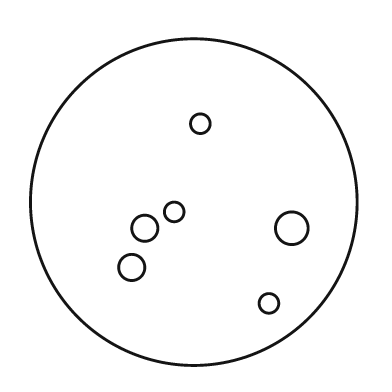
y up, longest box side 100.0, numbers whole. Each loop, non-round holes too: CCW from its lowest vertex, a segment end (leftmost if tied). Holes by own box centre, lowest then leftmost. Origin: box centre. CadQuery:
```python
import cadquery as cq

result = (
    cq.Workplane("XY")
    .moveTo(0.0, 0.0)
    .circle(50.0)
    .moveTo(23.0, -31.0)
    .circle(3.0)
    .moveTo(-19.0, -20.0)
    .circle(4.0)
    .moveTo(-15.0, -8.0)
    .circle(4.0)
    .moveTo(30.0, -8.0)
    .circle(5.0)
    .moveTo(-6.0, -3.0)
    .circle(3.0)
    .moveTo(2.0, 24.0)
    .circle(3.0)
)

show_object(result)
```